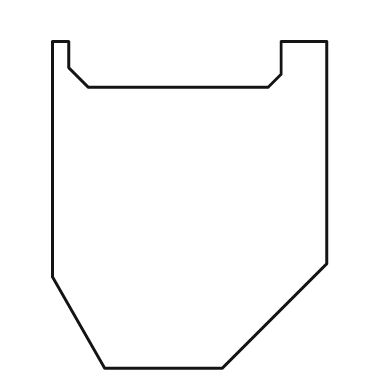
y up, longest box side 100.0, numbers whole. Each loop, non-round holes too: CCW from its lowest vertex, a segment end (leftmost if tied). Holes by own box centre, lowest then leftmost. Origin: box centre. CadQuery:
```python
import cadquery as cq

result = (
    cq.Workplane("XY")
    .moveTo(-26.0, -50.0)
    .lineTo(10.0, -50.0)
    .lineTo(42.0, -18.0)
    .lineTo(42.0, 50.0)
    .lineTo(28.0, 50.0)
    .lineTo(28.0, 40.0)
    .lineTo(24.0, 36.0)
    .lineTo(-31.0, 36.0)
    .lineTo(-37.0, 42.0)
    .lineTo(-37.0, 50.0)
    .lineTo(-42.0, 50.0)
    .lineTo(-42.0, -22.0)
    .close()
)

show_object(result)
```